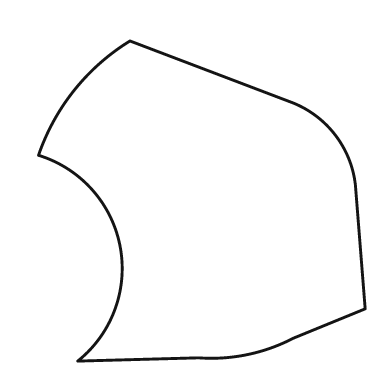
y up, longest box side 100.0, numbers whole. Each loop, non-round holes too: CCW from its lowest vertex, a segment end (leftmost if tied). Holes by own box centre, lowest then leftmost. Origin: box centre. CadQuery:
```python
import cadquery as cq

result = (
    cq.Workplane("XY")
    .moveTo(-38.0, -49.0)
    .lineTo(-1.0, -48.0)
    .threePointArc((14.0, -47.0), (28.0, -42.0))
    .lineTo(50.0, -33.0)
    .lineTo(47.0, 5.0)
    .threePointArc((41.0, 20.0), (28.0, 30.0))
    .lineTo(-22.0, 49.0)
    .threePointArc((-39.0, 34.0), (-50.0, 14.0))
    .threePointArc((-25.0, -14.0), (-38.0, -49.0))
    .close()
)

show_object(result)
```